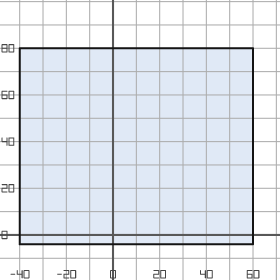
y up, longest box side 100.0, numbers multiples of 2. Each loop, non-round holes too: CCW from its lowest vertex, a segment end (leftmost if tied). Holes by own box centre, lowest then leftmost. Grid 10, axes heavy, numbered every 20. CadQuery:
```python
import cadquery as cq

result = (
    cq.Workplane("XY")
    .moveTo(-40.0, -4.0)
    .lineTo(60.0, -4.0)
    .lineTo(60.0, 80.0)
    .lineTo(-40.0, 80.0)
    .close()
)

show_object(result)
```